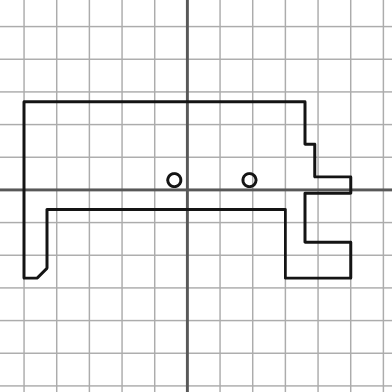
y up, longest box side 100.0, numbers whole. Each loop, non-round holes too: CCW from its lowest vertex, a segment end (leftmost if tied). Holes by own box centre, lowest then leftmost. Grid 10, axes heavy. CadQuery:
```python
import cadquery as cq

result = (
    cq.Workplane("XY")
    .moveTo(-50.0, -27.0)
    .lineTo(-46.0, -27.0)
    .lineTo(-43.0, -24.0)
    .lineTo(-43.0, -6.0)
    .lineTo(30.0, -6.0)
    .lineTo(30.0, -27.0)
    .lineTo(50.0, -27.0)
    .lineTo(50.0, -16.0)
    .lineTo(36.0, -16.0)
    .lineTo(36.0, -1.0)
    .lineTo(50.0, -1.0)
    .lineTo(50.0, 4.0)
    .lineTo(39.0, 4.0)
    .lineTo(39.0, 14.0)
    .lineTo(36.0, 14.0)
    .lineTo(36.0, 27.0)
    .lineTo(-50.0, 27.0)
    .close()
    .moveTo(-4.0, 3.0)
    .circle(2.0)
    .moveTo(19.0, 3.0)
    .circle(2.0)
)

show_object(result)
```